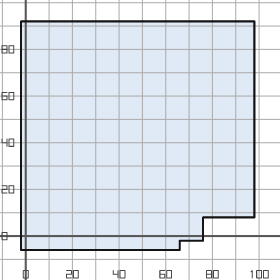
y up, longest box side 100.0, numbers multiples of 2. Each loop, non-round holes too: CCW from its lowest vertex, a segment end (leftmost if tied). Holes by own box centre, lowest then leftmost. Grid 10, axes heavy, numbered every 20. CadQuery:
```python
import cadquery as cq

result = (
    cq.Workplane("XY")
    .moveTo(-2.0, -6.0)
    .lineTo(66.0, -6.0)
    .lineTo(66.0, -2.0)
    .lineTo(76.0, -2.0)
    .lineTo(76.0, 8.0)
    .lineTo(98.0, 8.0)
    .lineTo(98.0, 92.0)
    .lineTo(-2.0, 92.0)
    .close()
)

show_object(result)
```